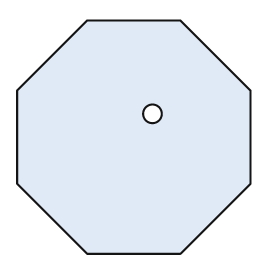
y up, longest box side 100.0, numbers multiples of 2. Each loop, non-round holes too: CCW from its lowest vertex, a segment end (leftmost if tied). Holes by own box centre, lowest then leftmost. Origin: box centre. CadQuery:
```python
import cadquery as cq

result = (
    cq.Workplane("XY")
    .moveTo(-20.0, -50.0)
    .lineTo(20.0, -50.0)
    .lineTo(50.0, -20.0)
    .lineTo(50.0, 20.0)
    .lineTo(20.0, 50.0)
    .lineTo(-20.0, 50.0)
    .lineTo(-50.0, 20.0)
    .lineTo(-50.0, -20.0)
    .close()
    .moveTo(8.0, 10.0)
    .circle(4.0)
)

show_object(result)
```